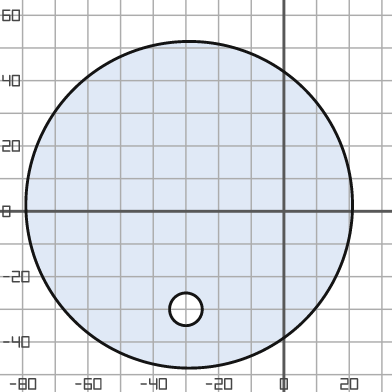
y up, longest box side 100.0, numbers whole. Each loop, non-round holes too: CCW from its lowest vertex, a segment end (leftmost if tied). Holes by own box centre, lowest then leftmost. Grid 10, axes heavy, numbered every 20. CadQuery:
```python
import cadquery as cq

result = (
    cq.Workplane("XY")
    .moveTo(-29.0, 2.0)
    .circle(50.0)
    .moveTo(-30.0, -30.0)
    .circle(5.0)
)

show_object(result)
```